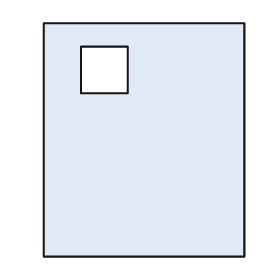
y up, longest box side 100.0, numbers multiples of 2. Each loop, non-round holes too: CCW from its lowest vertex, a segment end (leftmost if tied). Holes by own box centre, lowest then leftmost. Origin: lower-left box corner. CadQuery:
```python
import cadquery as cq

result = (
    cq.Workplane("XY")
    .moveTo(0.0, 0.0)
    .lineTo(86.0, 0.0)
    .lineTo(86.0, 100.0)
    .lineTo(0.0, 100.0)
    .close()
    .moveTo(16.0, 70.0)
    .lineTo(36.0, 70.0)
    .lineTo(36.0, 90.0)
    .lineTo(16.0, 90.0)
    .close()
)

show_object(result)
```